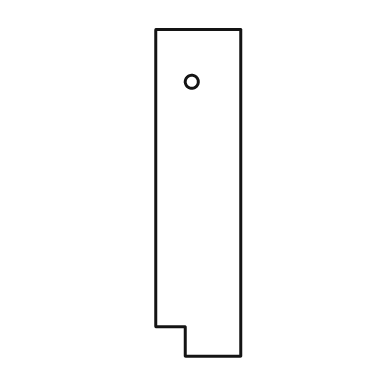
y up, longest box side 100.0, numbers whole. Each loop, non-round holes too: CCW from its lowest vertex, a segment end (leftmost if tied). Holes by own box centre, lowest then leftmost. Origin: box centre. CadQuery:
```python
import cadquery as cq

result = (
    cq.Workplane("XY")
    .moveTo(-4.0, -50.0)
    .lineTo(13.0, -50.0)
    .lineTo(13.0, 50.0)
    .lineTo(-13.0, 50.0)
    .lineTo(-13.0, -41.0)
    .lineTo(-4.0, -41.0)
    .close()
    .moveTo(-2.0, 34.0)
    .circle(2.0)
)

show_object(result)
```